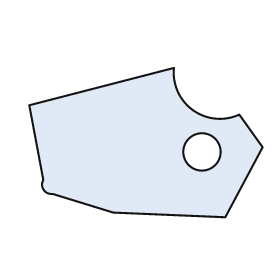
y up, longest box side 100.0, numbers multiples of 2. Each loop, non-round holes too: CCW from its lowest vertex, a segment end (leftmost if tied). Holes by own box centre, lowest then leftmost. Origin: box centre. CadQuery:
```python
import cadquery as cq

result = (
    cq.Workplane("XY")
    .moveTo(34.0, -32.0)
    .lineTo(50.0, -2.0)
    .lineTo(40.0, 12.0)
    .threePointArc((20.0, 14.0), (12.0, 32.0))
    .lineTo(-50.0, 16.0)
    .lineTo(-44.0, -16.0)
    .threePointArc((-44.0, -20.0), (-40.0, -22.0))
    .lineTo(-14.0, -30.0)
    .close()
    .moveTo(24.0, -4.0)
    .circle(8.0)
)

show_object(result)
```